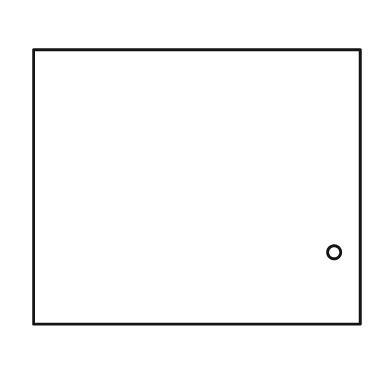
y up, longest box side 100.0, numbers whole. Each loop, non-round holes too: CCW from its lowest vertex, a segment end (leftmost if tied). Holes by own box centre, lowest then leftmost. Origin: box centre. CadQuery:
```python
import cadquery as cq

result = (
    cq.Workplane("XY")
    .moveTo(-50.0, -42.0)
    .lineTo(50.0, -42.0)
    .lineTo(50.0, 42.0)
    .lineTo(-50.0, 42.0)
    .close()
    .moveTo(42.0, -20.0)
    .circle(2.0)
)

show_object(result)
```